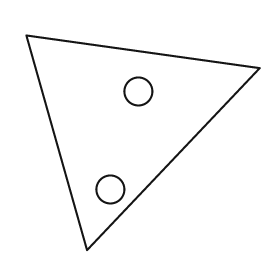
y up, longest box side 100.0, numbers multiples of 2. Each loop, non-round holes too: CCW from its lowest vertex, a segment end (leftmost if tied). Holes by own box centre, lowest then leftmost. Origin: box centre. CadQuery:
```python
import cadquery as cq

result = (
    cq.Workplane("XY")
    .moveTo(-24.0, -46.0)
    .lineTo(50.0, 32.0)
    .lineTo(-50.0, 46.0)
    .close()
    .moveTo(-14.0, -20.0)
    .circle(6.0)
    .moveTo(-2.0, 22.0)
    .circle(6.0)
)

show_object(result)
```